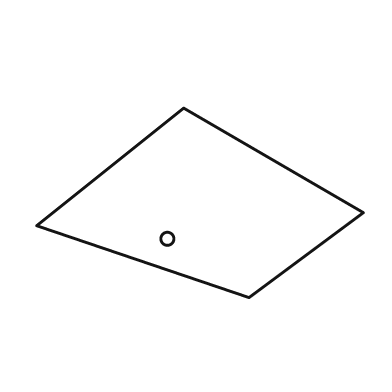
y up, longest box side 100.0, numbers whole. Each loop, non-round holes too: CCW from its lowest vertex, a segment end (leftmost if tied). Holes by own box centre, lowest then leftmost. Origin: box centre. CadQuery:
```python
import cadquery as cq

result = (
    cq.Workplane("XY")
    .moveTo(15.0, -29.0)
    .lineTo(50.0, -3.0)
    .lineTo(-5.0, 29.0)
    .lineTo(-50.0, -7.0)
    .close()
    .moveTo(-10.0, -11.0)
    .circle(2.0)
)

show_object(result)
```